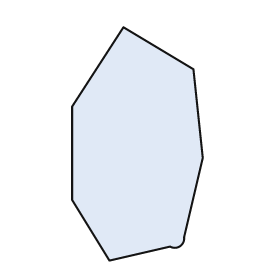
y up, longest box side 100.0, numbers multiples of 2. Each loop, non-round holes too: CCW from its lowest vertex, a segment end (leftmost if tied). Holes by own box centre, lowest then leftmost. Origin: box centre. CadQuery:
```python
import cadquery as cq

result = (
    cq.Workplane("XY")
    .moveTo(-12.0, -50.0)
    .lineTo(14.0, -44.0)
    .threePointArc((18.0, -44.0), (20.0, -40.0))
    .lineTo(28.0, -6.0)
    .lineTo(24.0, 32.0)
    .lineTo(-6.0, 50.0)
    .lineTo(-28.0, 16.0)
    .lineTo(-28.0, -24.0)
    .close()
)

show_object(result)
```